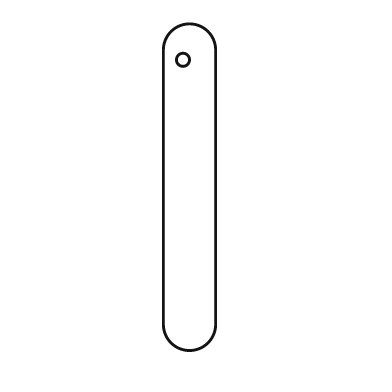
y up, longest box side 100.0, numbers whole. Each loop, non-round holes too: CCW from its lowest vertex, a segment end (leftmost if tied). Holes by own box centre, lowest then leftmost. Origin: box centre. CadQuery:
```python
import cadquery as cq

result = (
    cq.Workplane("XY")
    .moveTo(-8.0, -42.0)
    .threePointArc((0.0, -50.0), (8.0, -42.0))
    .lineTo(8.0, 42.0)
    .threePointArc((0.0, 50.0), (-8.0, 42.0))
    .close()
    .moveTo(-2.0, 39.0)
    .circle(2.0)
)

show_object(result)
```